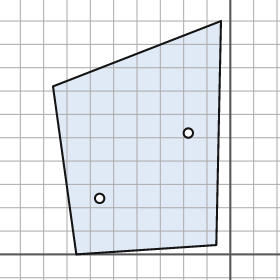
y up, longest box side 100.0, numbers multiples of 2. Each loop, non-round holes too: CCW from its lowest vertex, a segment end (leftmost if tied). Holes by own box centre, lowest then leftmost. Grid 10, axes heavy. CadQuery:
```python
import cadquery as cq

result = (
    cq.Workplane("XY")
    .moveTo(-66.0, 0.0)
    .lineTo(-6.0, 4.0)
    .lineTo(-4.0, 100.0)
    .lineTo(-76.0, 72.0)
    .close()
    .moveTo(-56.0, 24.0)
    .circle(2.0)
    .moveTo(-18.0, 52.0)
    .circle(2.0)
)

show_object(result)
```